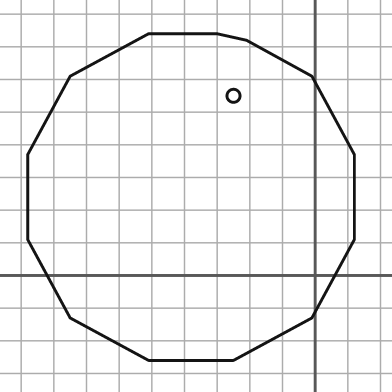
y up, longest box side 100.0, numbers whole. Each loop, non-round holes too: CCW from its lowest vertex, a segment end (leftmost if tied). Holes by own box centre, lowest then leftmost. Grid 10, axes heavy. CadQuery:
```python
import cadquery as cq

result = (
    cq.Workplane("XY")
    .moveTo(-51.0, -26.0)
    .lineTo(-25.0, -26.0)
    .lineTo(-1.0, -13.0)
    .lineTo(12.0, 11.0)
    .lineTo(12.0, 37.0)
    .lineTo(-1.0, 61.0)
    .lineTo(-21.0, 72.0)
    .lineTo(-30.0, 74.0)
    .lineTo(-51.0, 74.0)
    .lineTo(-75.0, 61.0)
    .lineTo(-88.0, 37.0)
    .lineTo(-88.0, 11.0)
    .lineTo(-75.0, -13.0)
    .close()
    .moveTo(-25.0, 55.0)
    .circle(2.0)
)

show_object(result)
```